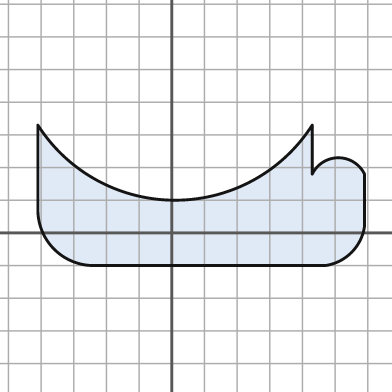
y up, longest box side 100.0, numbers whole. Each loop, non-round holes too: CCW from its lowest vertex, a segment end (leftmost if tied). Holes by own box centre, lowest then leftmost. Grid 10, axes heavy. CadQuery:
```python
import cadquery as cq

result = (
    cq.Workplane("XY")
    .moveTo(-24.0, -10.0)
    .lineTo(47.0, -10.0)
    .threePointArc((55.0, -6.0), (59.0, 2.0))
    .lineTo(59.0, 18.0)
    .threePointArc((51.0, 23.0), (43.0, 18.0))
    .lineTo(43.0, 33.0)
    .threePointArc((1.0, 10.0), (-41.0, 33.0))
    .lineTo(-41.0, 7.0)
    .threePointArc((-36.0, -5.0), (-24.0, -10.0))
    .close()
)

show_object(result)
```